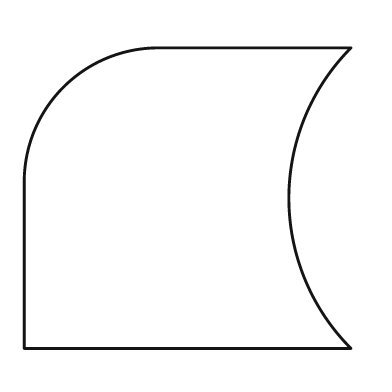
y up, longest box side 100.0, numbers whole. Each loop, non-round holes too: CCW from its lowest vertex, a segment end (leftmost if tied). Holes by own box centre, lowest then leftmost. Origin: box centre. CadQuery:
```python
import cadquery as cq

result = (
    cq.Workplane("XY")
    .moveTo(-50.0, -46.0)
    .lineTo(50.0, -46.0)
    .threePointArc((31.0, 0.0), (50.0, 46.0))
    .lineTo(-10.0, 46.0)
    .threePointArc((-38.0, 34.0), (-50.0, 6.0))
    .close()
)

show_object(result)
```